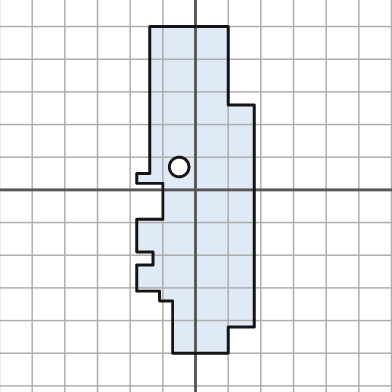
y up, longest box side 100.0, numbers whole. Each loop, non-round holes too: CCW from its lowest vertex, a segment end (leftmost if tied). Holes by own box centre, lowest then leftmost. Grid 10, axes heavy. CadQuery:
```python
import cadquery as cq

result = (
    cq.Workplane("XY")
    .moveTo(-7.0, -50.0)
    .lineTo(10.0, -50.0)
    .lineTo(10.0, -42.0)
    .lineTo(18.0, -42.0)
    .lineTo(18.0, 26.0)
    .lineTo(10.0, 26.0)
    .lineTo(10.0, 50.0)
    .lineTo(-14.0, 50.0)
    .lineTo(-14.0, 5.0)
    .lineTo(-18.0, 5.0)
    .lineTo(-18.0, 2.0)
    .lineTo(-10.0, 2.0)
    .lineTo(-10.0, -9.0)
    .lineTo(-18.0, -9.0)
    .lineTo(-18.0, -19.0)
    .lineTo(-13.0, -19.0)
    .lineTo(-13.0, -23.0)
    .lineTo(-18.0, -23.0)
    .lineTo(-18.0, -31.0)
    .lineTo(-11.0, -31.0)
    .lineTo(-11.0, -34.0)
    .lineTo(-7.0, -34.0)
    .close()
    .moveTo(-5.0, 7.0)
    .circle(3.0)
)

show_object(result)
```